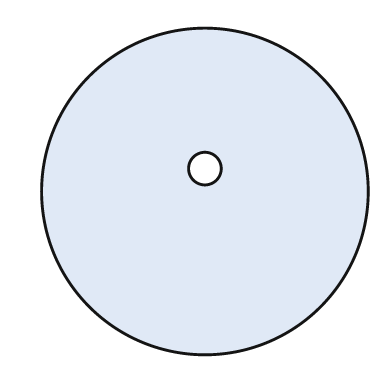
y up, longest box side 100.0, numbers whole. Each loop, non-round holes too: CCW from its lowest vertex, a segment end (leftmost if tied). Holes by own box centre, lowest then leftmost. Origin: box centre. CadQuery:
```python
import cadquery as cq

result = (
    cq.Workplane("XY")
    .moveTo(0.0, 0.0)
    .circle(50.0)
    .moveTo(0.0, 7.0)
    .circle(5.0)
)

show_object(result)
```